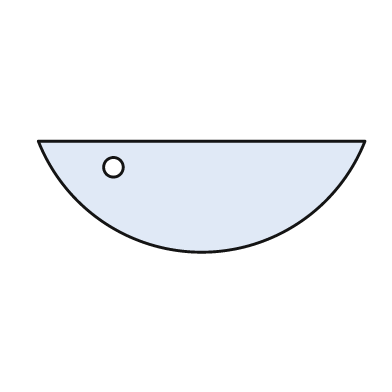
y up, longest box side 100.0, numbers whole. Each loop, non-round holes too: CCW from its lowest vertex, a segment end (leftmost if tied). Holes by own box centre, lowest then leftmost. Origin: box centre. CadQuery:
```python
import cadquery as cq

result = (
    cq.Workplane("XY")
    .moveTo(-50.0, 17.0)
    .threePointArc((0.0, -17.0), (50.0, 17.0))
    .close()
    .moveTo(-27.0, 9.0)
    .circle(3.0)
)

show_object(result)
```